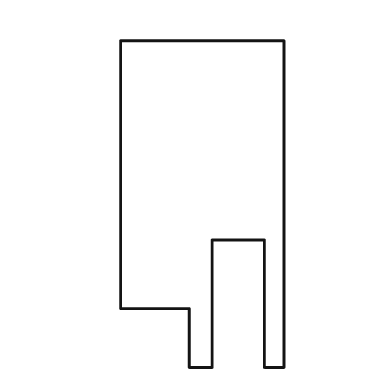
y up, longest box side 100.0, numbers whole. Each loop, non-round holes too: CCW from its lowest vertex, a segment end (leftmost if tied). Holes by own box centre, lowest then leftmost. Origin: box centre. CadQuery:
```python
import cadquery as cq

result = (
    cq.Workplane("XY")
    .moveTo(-4.0, -50.0)
    .lineTo(3.0, -50.0)
    .lineTo(3.0, -11.0)
    .lineTo(19.0, -11.0)
    .lineTo(19.0, -50.0)
    .lineTo(25.0, -50.0)
    .lineTo(25.0, 50.0)
    .lineTo(-25.0, 50.0)
    .lineTo(-25.0, -32.0)
    .lineTo(-4.0, -32.0)
    .close()
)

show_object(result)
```